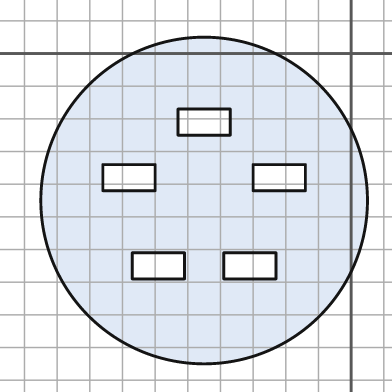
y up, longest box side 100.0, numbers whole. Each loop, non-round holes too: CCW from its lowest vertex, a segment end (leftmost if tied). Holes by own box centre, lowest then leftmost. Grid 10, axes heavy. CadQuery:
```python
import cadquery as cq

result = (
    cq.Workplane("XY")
    .moveTo(-45.0, -45.0)
    .circle(50.0)
    .moveTo(-67.0, -69.0)
    .lineTo(-51.0, -69.0)
    .lineTo(-51.0, -61.0)
    .lineTo(-67.0, -61.0)
    .close()
    .moveTo(-39.0, -69.0)
    .lineTo(-23.0, -69.0)
    .lineTo(-23.0, -61.0)
    .lineTo(-39.0, -61.0)
    .close()
    .moveTo(-76.0, -42.0)
    .lineTo(-60.0, -42.0)
    .lineTo(-60.0, -34.0)
    .lineTo(-76.0, -34.0)
    .close()
    .moveTo(-30.0, -42.0)
    .lineTo(-14.0, -42.0)
    .lineTo(-14.0, -34.0)
    .lineTo(-30.0, -34.0)
    .close()
    .moveTo(-53.0, -25.0)
    .lineTo(-37.0, -25.0)
    .lineTo(-37.0, -17.0)
    .lineTo(-53.0, -17.0)
    .close()
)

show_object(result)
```